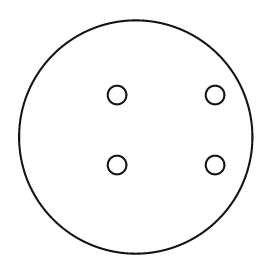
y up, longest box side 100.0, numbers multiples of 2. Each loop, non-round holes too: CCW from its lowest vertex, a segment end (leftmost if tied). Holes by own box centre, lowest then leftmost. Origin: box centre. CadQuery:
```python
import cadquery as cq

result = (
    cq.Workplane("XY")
    .moveTo(0.0, 0.0)
    .circle(50.0)
    .moveTo(-8.0, -12.0)
    .circle(4.0)
    .moveTo(34.0, -12.0)
    .circle(4.0)
    .moveTo(-8.0, 18.0)
    .circle(4.0)
    .moveTo(34.0, 18.0)
    .circle(4.0)
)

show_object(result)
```